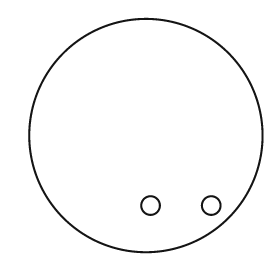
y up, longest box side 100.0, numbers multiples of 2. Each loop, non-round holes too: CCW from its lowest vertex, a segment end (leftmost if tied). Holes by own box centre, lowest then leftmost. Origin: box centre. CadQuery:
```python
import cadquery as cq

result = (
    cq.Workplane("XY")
    .moveTo(0.0, 0.0)
    .circle(50.0)
    .moveTo(2.0, -30.0)
    .circle(4.0)
    .moveTo(28.0, -30.0)
    .circle(4.0)
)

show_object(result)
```